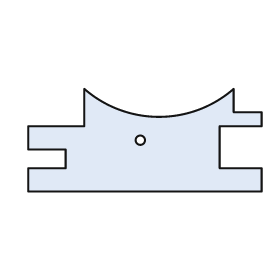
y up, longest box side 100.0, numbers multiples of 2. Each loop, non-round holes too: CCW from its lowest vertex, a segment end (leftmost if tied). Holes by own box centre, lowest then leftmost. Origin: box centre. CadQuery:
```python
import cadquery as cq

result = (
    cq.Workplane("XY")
    .moveTo(-50.0, -22.0)
    .lineTo(50.0, -22.0)
    .lineTo(50.0, -12.0)
    .lineTo(32.0, -12.0)
    .lineTo(32.0, 6.0)
    .lineTo(50.0, 6.0)
    .lineTo(50.0, 12.0)
    .lineTo(38.0, 12.0)
    .lineTo(38.0, 22.0)
    .threePointArc((6.0, 10.0), (-26.0, 22.0))
    .lineTo(-26.0, 6.0)
    .lineTo(-50.0, 6.0)
    .lineTo(-50.0, -4.0)
    .lineTo(-34.0, -4.0)
    .lineTo(-34.0, -12.0)
    .lineTo(-50.0, -12.0)
    .close()
    .moveTo(-2.0, 0.0)
    .circle(2.0)
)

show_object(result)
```